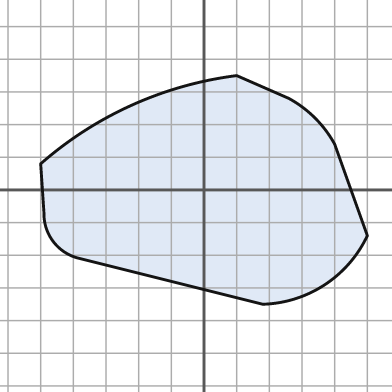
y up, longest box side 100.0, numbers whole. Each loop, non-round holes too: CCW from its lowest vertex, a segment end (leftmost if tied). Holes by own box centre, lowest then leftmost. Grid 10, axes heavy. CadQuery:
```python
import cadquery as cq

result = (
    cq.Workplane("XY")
    .moveTo(18.0, -35.0)
    .threePointArc((37.0, -29.0), (50.0, -14.0))
    .lineTo(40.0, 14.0)
    .threePointArc((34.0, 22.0), (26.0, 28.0))
    .lineTo(10.0, 35.0)
    .threePointArc((-22.0, 26.0), (-50.0, 8.0))
    .lineTo(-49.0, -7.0)
    .threePointArc((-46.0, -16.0), (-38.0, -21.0))
    .close()
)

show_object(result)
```